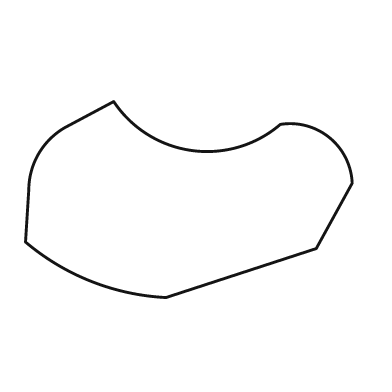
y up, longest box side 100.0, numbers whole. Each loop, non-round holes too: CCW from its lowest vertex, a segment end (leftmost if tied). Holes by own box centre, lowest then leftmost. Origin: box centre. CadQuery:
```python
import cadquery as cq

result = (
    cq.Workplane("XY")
    .moveTo(-7.0, -30.0)
    .lineTo(39.0, -15.0)
    .lineTo(50.0, 5.0)
    .threePointArc((43.0, 19.0), (28.0, 23.0))
    .threePointArc((1.0, 15.0), (-23.0, 30.0))
    .lineTo(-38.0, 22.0)
    .threePointArc((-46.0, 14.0), (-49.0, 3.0))
    .lineTo(-50.0, -13.0)
    .threePointArc((-30.0, -25.0), (-7.0, -30.0))
    .close()
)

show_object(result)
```